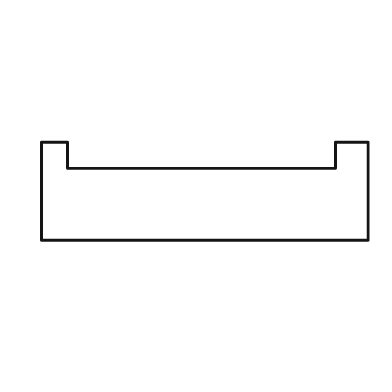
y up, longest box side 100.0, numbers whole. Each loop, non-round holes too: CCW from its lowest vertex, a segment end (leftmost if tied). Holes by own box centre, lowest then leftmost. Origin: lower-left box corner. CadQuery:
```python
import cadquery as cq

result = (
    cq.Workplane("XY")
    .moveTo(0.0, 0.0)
    .lineTo(100.0, 0.0)
    .lineTo(100.0, 30.0)
    .lineTo(90.0, 30.0)
    .lineTo(90.0, 22.0)
    .lineTo(8.0, 22.0)
    .lineTo(8.0, 30.0)
    .lineTo(0.0, 30.0)
    .close()
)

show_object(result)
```